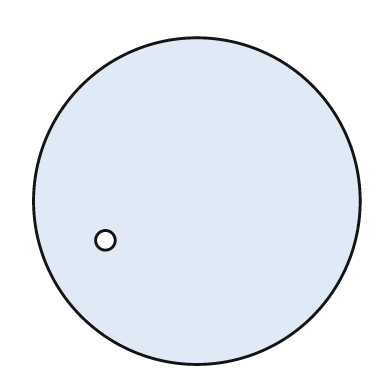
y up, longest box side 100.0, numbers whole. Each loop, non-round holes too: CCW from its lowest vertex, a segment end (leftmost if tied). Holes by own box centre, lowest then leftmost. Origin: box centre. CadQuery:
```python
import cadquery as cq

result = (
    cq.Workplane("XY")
    .moveTo(0.0, 0.0)
    .circle(50.0)
    .moveTo(-28.0, -12.0)
    .circle(3.0)
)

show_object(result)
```